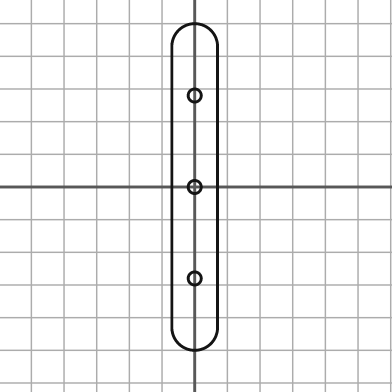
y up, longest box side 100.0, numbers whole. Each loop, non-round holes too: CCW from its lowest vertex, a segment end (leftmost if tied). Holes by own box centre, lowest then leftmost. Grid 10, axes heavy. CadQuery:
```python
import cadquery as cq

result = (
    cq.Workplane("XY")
    .moveTo(-7.0, -43.0)
    .threePointArc((0.0, -50.0), (7.0, -43.0))
    .lineTo(7.0, 43.0)
    .threePointArc((0.0, 50.0), (-7.0, 43.0))
    .close()
    .moveTo(0.0, -28.0)
    .circle(2.0)
    .moveTo(0.0, 0.0)
    .circle(2.0)
    .moveTo(0.0, 28.0)
    .circle(2.0)
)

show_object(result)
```